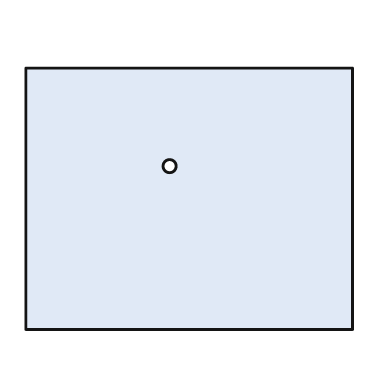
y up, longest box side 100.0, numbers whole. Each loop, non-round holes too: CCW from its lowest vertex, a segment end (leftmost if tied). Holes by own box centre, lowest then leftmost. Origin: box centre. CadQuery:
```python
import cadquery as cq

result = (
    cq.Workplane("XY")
    .moveTo(-50.0, -40.0)
    .lineTo(50.0, -40.0)
    .lineTo(50.0, 40.0)
    .lineTo(-50.0, 40.0)
    .close()
    .moveTo(-6.0, 10.0)
    .circle(2.0)
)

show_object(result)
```